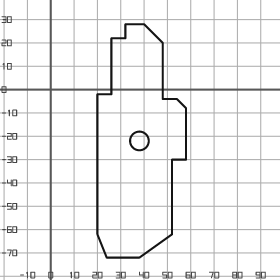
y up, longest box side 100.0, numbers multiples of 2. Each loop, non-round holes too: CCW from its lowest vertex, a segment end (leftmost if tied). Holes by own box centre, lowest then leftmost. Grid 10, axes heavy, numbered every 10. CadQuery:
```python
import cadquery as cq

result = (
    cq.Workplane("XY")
    .moveTo(24.0, -72.0)
    .lineTo(38.0, -72.0)
    .lineTo(52.0, -62.0)
    .lineTo(52.0, -30.0)
    .lineTo(58.0, -30.0)
    .lineTo(58.0, -8.0)
    .lineTo(54.0, -4.0)
    .lineTo(48.0, -4.0)
    .lineTo(48.0, 20.0)
    .lineTo(40.0, 28.0)
    .lineTo(32.0, 28.0)
    .lineTo(32.0, 22.0)
    .lineTo(26.0, 22.0)
    .lineTo(26.0, -2.0)
    .lineTo(20.0, -2.0)
    .lineTo(20.0, -62.0)
    .close()
    .moveTo(38.0, -22.0)
    .circle(4.0)
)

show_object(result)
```